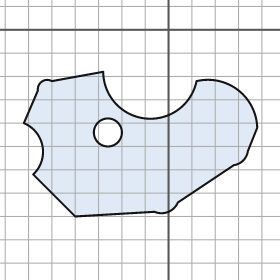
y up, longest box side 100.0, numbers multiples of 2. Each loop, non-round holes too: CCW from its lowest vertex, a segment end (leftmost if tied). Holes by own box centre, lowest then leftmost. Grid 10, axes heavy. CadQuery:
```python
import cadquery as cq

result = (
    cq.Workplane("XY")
    .moveTo(-40.0, -80.0)
    .lineTo(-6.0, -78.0)
    .threePointArc((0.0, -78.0), (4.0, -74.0))
    .lineTo(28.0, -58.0)
    .threePointArc((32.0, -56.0), (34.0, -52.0))
    .lineTo(38.0, -42.0)
    .threePointArc((30.0, -26.0), (12.0, -22.0))
    .threePointArc((-10.0, -38.0), (-28.0, -18.0))
    .lineTo(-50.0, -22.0)
    .threePointArc((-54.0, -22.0), (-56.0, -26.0))
    .lineTo(-62.0, -40.0)
    .threePointArc((-54.0, -50.0), (-58.0, -62.0))
    .close()
    .moveTo(-26.0, -44.0)
    .circle(6.0)
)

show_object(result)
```